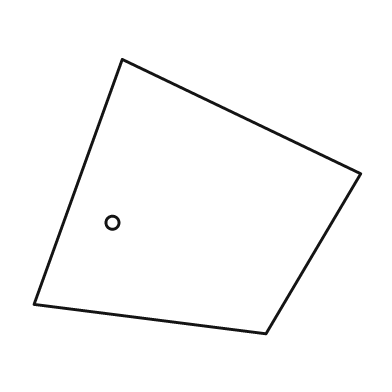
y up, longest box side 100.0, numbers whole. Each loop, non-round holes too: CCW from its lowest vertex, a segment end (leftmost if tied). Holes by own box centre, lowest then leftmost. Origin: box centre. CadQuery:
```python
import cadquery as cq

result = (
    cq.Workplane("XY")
    .moveTo(21.0, -42.0)
    .lineTo(50.0, 7.0)
    .lineTo(-23.0, 42.0)
    .lineTo(-50.0, -33.0)
    .close()
    .moveTo(-26.0, -8.0)
    .circle(2.0)
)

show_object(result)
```